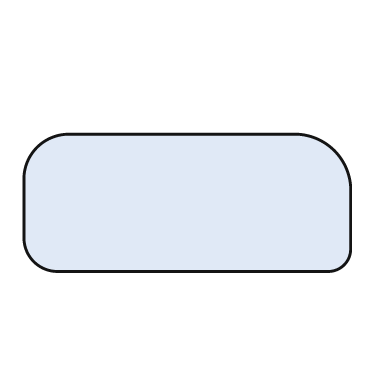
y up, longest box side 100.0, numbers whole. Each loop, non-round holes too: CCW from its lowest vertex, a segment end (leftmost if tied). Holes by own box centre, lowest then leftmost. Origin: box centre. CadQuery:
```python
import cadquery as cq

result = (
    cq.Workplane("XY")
    .moveTo(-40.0, -21.0)
    .lineTo(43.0, -21.0)
    .threePointArc((48.0, -19.0), (50.0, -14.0))
    .lineTo(50.0, 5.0)
    .threePointArc((45.0, 16.0), (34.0, 21.0))
    .lineTo(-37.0, 21.0)
    .threePointArc((-46.0, 17.0), (-50.0, 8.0))
    .lineTo(-50.0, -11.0)
    .threePointArc((-47.0, -18.0), (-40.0, -21.0))
    .close()
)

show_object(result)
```